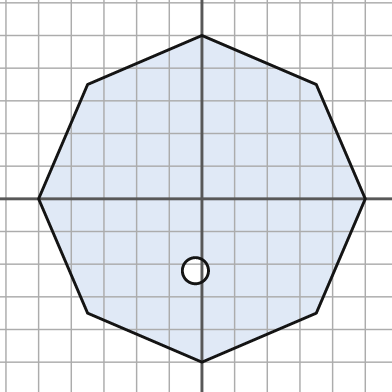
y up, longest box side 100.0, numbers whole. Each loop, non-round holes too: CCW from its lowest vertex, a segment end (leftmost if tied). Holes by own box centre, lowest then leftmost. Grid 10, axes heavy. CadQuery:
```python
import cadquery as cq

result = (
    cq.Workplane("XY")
    .moveTo(0.0, -50.0)
    .lineTo(35.0, -35.0)
    .lineTo(50.0, 0.0)
    .lineTo(35.0, 35.0)
    .lineTo(0.0, 50.0)
    .lineTo(-35.0, 35.0)
    .lineTo(-50.0, 0.0)
    .lineTo(-35.0, -35.0)
    .close()
    .moveTo(-2.0, -22.0)
    .circle(4.0)
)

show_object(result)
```